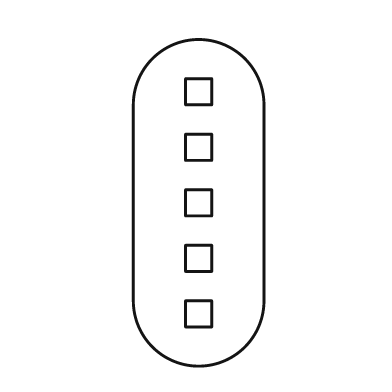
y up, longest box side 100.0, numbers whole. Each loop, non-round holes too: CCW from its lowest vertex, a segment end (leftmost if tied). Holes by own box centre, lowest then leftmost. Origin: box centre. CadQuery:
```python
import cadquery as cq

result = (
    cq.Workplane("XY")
    .moveTo(-20.0, -30.0)
    .threePointArc((0.0, -50.0), (20.0, -30.0))
    .lineTo(20.0, 30.0)
    .threePointArc((0.0, 50.0), (-20.0, 30.0))
    .close()
    .moveTo(-4.0, -38.0)
    .lineTo(4.0, -38.0)
    .lineTo(4.0, -30.0)
    .lineTo(-4.0, -30.0)
    .close()
    .moveTo(-4.0, -21.0)
    .lineTo(4.0, -21.0)
    .lineTo(4.0, -13.0)
    .lineTo(-4.0, -13.0)
    .close()
    .moveTo(-4.0, -4.0)
    .lineTo(4.0, -4.0)
    .lineTo(4.0, 4.0)
    .lineTo(-4.0, 4.0)
    .close()
    .moveTo(-4.0, 13.0)
    .lineTo(4.0, 13.0)
    .lineTo(4.0, 21.0)
    .lineTo(-4.0, 21.0)
    .close()
    .moveTo(-4.0, 30.0)
    .lineTo(4.0, 30.0)
    .lineTo(4.0, 38.0)
    .lineTo(-4.0, 38.0)
    .close()
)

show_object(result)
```